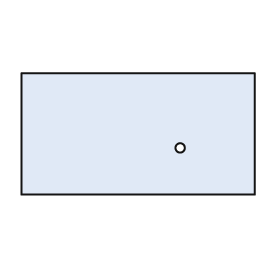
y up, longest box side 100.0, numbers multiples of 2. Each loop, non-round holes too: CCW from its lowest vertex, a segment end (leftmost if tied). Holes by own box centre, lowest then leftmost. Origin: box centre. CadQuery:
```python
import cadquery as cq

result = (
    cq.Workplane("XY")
    .moveTo(-50.0, -26.0)
    .lineTo(50.0, -26.0)
    .lineTo(50.0, 26.0)
    .lineTo(-50.0, 26.0)
    .close()
    .moveTo(18.0, -6.0)
    .circle(2.0)
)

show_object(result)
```